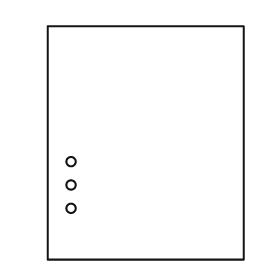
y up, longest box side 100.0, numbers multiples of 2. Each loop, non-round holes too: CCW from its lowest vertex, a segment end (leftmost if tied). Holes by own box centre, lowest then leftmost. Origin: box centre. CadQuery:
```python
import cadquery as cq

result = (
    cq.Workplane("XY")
    .moveTo(-42.0, -50.0)
    .lineTo(42.0, -50.0)
    .lineTo(42.0, 50.0)
    .lineTo(-42.0, 50.0)
    .close()
    .moveTo(-32.0, -28.0)
    .circle(2.0)
    .moveTo(-32.0, -18.0)
    .circle(2.0)
    .moveTo(-32.0, -8.0)
    .circle(2.0)
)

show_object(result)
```